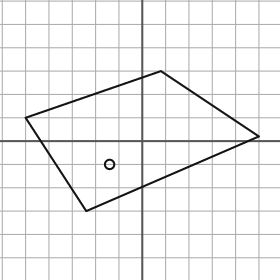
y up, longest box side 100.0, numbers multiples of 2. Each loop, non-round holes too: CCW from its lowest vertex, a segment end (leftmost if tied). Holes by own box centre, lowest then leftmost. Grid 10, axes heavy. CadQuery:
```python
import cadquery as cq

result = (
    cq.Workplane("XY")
    .moveTo(-24.0, -30.0)
    .lineTo(50.0, 2.0)
    .lineTo(8.0, 30.0)
    .lineTo(-50.0, 10.0)
    .close()
    .moveTo(-14.0, -10.0)
    .circle(2.0)
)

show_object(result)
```